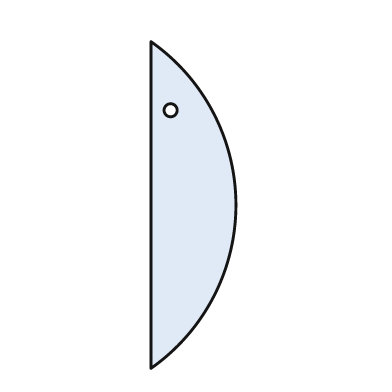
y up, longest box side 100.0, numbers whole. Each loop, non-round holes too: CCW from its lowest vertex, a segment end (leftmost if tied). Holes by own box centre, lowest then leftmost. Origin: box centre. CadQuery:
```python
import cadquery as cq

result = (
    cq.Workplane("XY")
    .moveTo(-13.0, -50.0)
    .threePointArc((13.0, 0.0), (-13.0, 50.0))
    .close()
    .moveTo(-7.0, 29.0)
    .circle(2.0)
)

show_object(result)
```